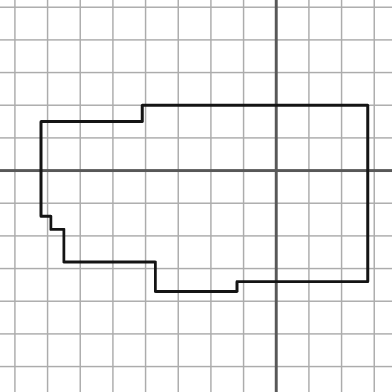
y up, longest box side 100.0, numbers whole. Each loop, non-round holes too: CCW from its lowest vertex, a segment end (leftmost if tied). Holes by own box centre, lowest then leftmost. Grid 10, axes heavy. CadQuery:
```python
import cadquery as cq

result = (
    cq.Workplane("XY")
    .moveTo(-37.0, -37.0)
    .lineTo(-12.0, -37.0)
    .lineTo(-12.0, -34.0)
    .lineTo(28.0, -34.0)
    .lineTo(28.0, 20.0)
    .lineTo(-41.0, 20.0)
    .lineTo(-41.0, 15.0)
    .lineTo(-72.0, 15.0)
    .lineTo(-72.0, -14.0)
    .lineTo(-69.0, -14.0)
    .lineTo(-69.0, -18.0)
    .lineTo(-65.0, -18.0)
    .lineTo(-65.0, -28.0)
    .lineTo(-37.0, -28.0)
    .close()
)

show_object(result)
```